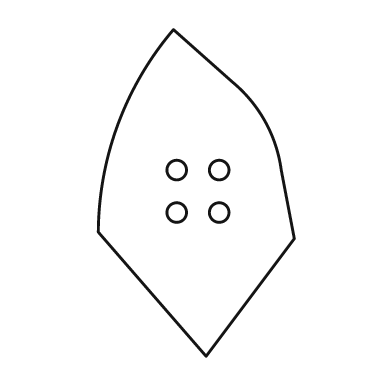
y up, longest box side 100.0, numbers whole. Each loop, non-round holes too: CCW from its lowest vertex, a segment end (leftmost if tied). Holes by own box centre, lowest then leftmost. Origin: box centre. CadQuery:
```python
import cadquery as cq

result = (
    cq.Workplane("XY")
    .moveTo(3.0, -50.0)
    .lineTo(30.0, -14.0)
    .lineTo(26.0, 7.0)
    .threePointArc((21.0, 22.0), (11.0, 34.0))
    .lineTo(-7.0, 50.0)
    .threePointArc((-24.0, 21.0), (-30.0, -12.0))
    .close()
    .moveTo(-6.0, -6.0)
    .circle(3.0)
    .moveTo(7.0, -6.0)
    .circle(3.0)
    .moveTo(-6.0, 7.0)
    .circle(3.0)
    .moveTo(7.0, 7.0)
    .circle(3.0)
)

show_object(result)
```